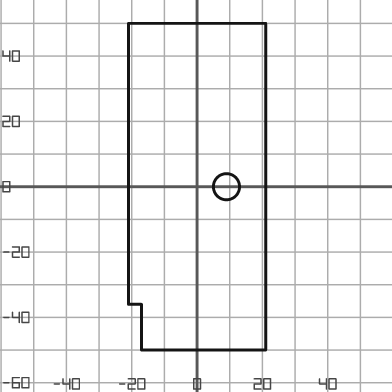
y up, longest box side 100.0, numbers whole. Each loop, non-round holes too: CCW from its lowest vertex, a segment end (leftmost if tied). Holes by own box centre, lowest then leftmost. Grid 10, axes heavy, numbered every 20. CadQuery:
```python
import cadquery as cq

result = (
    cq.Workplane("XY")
    .moveTo(-17.0, -50.0)
    .lineTo(21.0, -50.0)
    .lineTo(21.0, 50.0)
    .lineTo(-21.0, 50.0)
    .lineTo(-21.0, -36.0)
    .lineTo(-17.0, -36.0)
    .close()
    .moveTo(9.0, 0.0)
    .circle(4.0)
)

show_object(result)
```